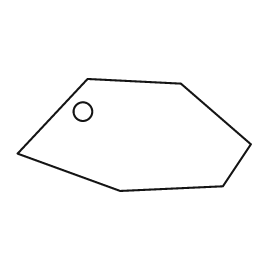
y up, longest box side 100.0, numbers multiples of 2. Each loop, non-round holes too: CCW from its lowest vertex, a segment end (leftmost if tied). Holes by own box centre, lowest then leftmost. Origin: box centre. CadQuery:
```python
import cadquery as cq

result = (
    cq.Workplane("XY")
    .moveTo(-6.0, -24.0)
    .lineTo(38.0, -22.0)
    .lineTo(50.0, -4.0)
    .lineTo(20.0, 22.0)
    .lineTo(-20.0, 24.0)
    .lineTo(-50.0, -8.0)
    .close()
    .moveTo(-22.0, 10.0)
    .circle(4.0)
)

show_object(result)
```